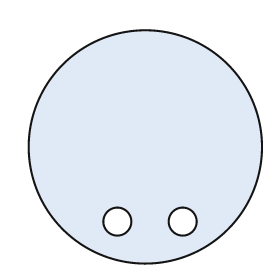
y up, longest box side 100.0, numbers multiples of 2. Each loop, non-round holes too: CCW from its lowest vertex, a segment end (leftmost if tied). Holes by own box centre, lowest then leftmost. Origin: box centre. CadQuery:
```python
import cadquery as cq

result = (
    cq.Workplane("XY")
    .moveTo(0.0, 0.0)
    .circle(50.0)
    .moveTo(-12.0, -32.0)
    .circle(6.0)
    .moveTo(16.0, -32.0)
    .circle(6.0)
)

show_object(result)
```